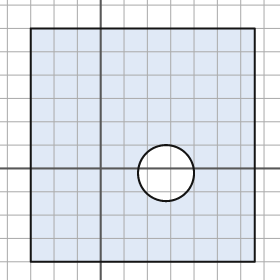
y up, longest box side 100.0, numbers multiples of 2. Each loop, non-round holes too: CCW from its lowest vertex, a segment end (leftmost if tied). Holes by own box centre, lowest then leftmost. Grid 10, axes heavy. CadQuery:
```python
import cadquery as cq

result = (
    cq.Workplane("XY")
    .moveTo(-30.0, -40.0)
    .lineTo(66.0, -40.0)
    .lineTo(66.0, 60.0)
    .lineTo(-30.0, 60.0)
    .close()
    .moveTo(28.0, -2.0)
    .circle(12.0)
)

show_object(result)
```